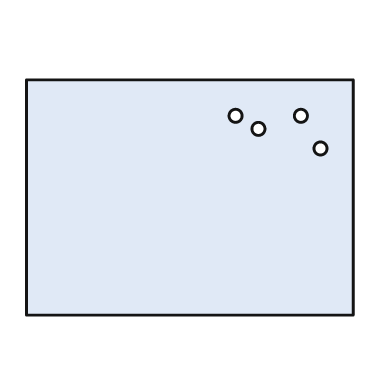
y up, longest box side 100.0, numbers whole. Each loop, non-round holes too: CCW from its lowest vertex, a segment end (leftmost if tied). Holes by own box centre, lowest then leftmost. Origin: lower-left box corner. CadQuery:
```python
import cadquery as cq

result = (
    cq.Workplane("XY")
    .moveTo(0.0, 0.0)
    .lineTo(100.0, 0.0)
    .lineTo(100.0, 72.0)
    .lineTo(0.0, 72.0)
    .close()
    .moveTo(90.0, 51.0)
    .circle(2.0)
    .moveTo(71.0, 57.0)
    .circle(2.0)
    .moveTo(64.0, 61.0)
    .circle(2.0)
    .moveTo(84.0, 61.0)
    .circle(2.0)
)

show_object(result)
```